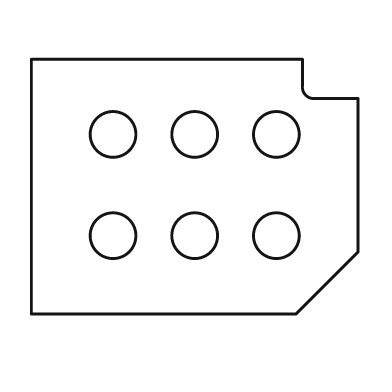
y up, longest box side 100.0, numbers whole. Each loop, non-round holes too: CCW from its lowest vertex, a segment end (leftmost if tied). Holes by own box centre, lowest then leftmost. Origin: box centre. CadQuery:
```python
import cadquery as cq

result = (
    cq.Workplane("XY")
    .moveTo(-50.0, -39.0)
    .lineTo(31.0, -39.0)
    .lineTo(50.0, -20.0)
    .lineTo(50.0, 27.0)
    .lineTo(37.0, 27.0)
    .threePointArc((34.0, 28.0), (33.0, 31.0))
    .lineTo(33.0, 39.0)
    .lineTo(-50.0, 39.0)
    .close()
    .moveTo(-25.0, -15.0)
    .circle(7.0)
    .moveTo(0.0, -15.0)
    .circle(7.0)
    .moveTo(25.0, -15.0)
    .circle(7.0)
    .moveTo(-25.0, 16.0)
    .circle(7.0)
    .moveTo(0.0, 16.0)
    .circle(7.0)
    .moveTo(25.0, 16.0)
    .circle(7.0)
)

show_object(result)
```